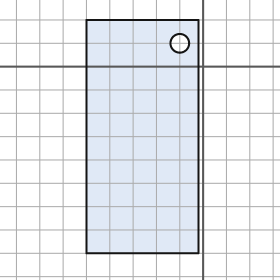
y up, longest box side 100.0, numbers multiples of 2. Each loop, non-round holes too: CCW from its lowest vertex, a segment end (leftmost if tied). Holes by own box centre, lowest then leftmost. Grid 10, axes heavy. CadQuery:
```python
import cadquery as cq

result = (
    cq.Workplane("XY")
    .moveTo(-50.0, -80.0)
    .lineTo(-2.0, -80.0)
    .lineTo(-2.0, 20.0)
    .lineTo(-50.0, 20.0)
    .close()
    .moveTo(-10.0, 10.0)
    .circle(4.0)
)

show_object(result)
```